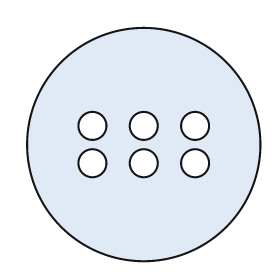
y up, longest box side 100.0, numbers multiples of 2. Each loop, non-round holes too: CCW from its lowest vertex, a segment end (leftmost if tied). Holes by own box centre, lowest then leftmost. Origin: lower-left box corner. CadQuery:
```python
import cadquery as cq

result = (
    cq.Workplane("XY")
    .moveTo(50.0, 50.0)
    .circle(50.0)
    .moveTo(28.0, 42.0)
    .circle(6.0)
    .moveTo(50.0, 42.0)
    .circle(6.0)
    .moveTo(72.0, 42.0)
    .circle(6.0)
    .moveTo(28.0, 58.0)
    .circle(6.0)
    .moveTo(50.0, 58.0)
    .circle(6.0)
    .moveTo(72.0, 58.0)
    .circle(6.0)
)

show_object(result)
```